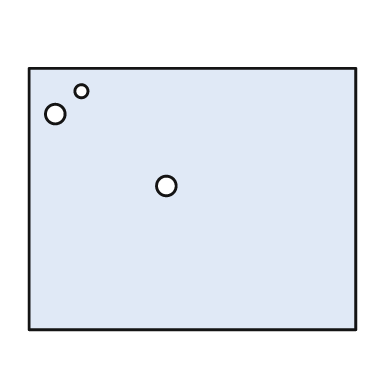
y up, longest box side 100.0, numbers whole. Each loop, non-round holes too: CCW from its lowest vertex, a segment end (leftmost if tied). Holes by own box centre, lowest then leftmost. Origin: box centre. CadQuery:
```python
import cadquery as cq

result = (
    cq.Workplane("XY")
    .moveTo(-50.0, -40.0)
    .lineTo(50.0, -40.0)
    .lineTo(50.0, 40.0)
    .lineTo(-50.0, 40.0)
    .close()
    .moveTo(-8.0, 4.0)
    .circle(3.0)
    .moveTo(-42.0, 26.0)
    .circle(3.0)
    .moveTo(-34.0, 33.0)
    .circle(2.0)
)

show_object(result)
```